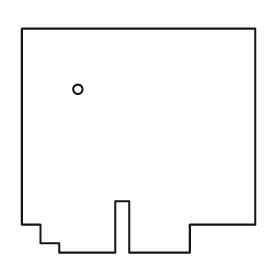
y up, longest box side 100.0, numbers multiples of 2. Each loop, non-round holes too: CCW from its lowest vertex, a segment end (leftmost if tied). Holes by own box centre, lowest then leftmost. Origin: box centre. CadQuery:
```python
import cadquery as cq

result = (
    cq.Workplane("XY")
    .moveTo(-34.0, -48.0)
    .lineTo(-10.0, -48.0)
    .lineTo(-10.0, -26.0)
    .lineTo(-4.0, -26.0)
    .lineTo(-4.0, -48.0)
    .lineTo(22.0, -48.0)
    .lineTo(22.0, -36.0)
    .lineTo(50.0, -36.0)
    .lineTo(50.0, 48.0)
    .lineTo(-50.0, 48.0)
    .lineTo(-50.0, -36.0)
    .lineTo(-42.0, -36.0)
    .lineTo(-42.0, -44.0)
    .lineTo(-34.0, -44.0)
    .close()
    .moveTo(-26.0, 22.0)
    .circle(2.0)
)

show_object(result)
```